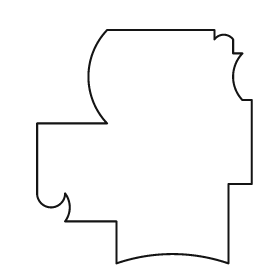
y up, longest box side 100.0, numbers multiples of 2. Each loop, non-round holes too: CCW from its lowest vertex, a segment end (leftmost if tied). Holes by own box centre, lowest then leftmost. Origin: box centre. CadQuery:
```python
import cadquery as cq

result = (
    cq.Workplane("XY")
    .moveTo(-12.0, -50.0)
    .threePointArc((12.0, -46.0), (36.0, -50.0))
    .lineTo(36.0, -16.0)
    .lineTo(46.0, -16.0)
    .lineTo(46.0, 20.0)
    .lineTo(42.0, 20.0)
    .threePointArc((38.0, 30.0), (42.0, 40.0))
    .lineTo(38.0, 40.0)
    .lineTo(38.0, 46.0)
    .threePointArc((34.0, 48.0), (30.0, 46.0))
    .lineTo(30.0, 50.0)
    .lineTo(-16.0, 50.0)
    .threePointArc((-24.0, 30.0), (-16.0, 10.0))
    .lineTo(-46.0, 10.0)
    .lineTo(-46.0, -20.0)
    .threePointArc((-40.0, -26.0), (-34.0, -20.0))
    .threePointArc((-32.0, -26.0), (-34.0, -32.0))
    .lineTo(-12.0, -32.0)
    .close()
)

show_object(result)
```